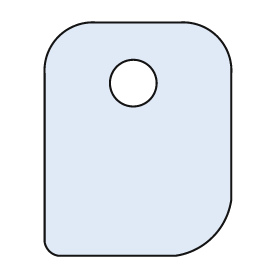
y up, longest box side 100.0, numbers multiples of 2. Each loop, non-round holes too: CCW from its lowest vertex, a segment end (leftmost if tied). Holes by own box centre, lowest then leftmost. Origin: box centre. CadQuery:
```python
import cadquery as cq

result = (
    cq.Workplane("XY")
    .moveTo(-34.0, -50.0)
    .lineTo(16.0, -50.0)
    .threePointArc((32.0, -42.0), (40.0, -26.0))
    .lineTo(40.0, 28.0)
    .threePointArc((34.0, 44.0), (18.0, 50.0))
    .lineTo(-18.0, 50.0)
    .threePointArc((-34.0, 44.0), (-40.0, 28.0))
    .lineTo(-40.0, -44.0)
    .threePointArc((-38.0, -48.0), (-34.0, -50.0))
    .close()
    .moveTo(-2.0, 24.0)
    .circle(10.0)
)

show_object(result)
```